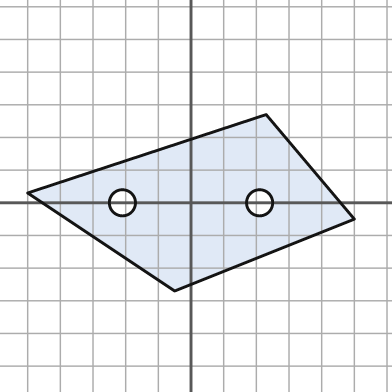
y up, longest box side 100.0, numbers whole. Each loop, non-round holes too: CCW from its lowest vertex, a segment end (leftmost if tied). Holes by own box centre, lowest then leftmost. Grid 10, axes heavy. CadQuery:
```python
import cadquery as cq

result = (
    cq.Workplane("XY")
    .moveTo(-5.0, -27.0)
    .lineTo(50.0, -5.0)
    .lineTo(23.0, 27.0)
    .lineTo(-50.0, 3.0)
    .close()
    .moveTo(-21.0, 0.0)
    .circle(4.0)
    .moveTo(21.0, 0.0)
    .circle(4.0)
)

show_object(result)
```